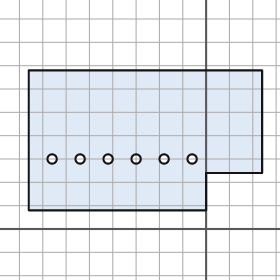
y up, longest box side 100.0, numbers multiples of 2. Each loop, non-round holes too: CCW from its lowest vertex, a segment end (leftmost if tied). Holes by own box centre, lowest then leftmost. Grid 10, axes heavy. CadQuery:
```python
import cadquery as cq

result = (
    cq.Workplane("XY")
    .moveTo(-76.0, 8.0)
    .lineTo(0.0, 8.0)
    .lineTo(0.0, 24.0)
    .lineTo(24.0, 24.0)
    .lineTo(24.0, 68.0)
    .lineTo(-76.0, 68.0)
    .close()
    .moveTo(-66.0, 30.0)
    .circle(2.0)
    .moveTo(-54.0, 30.0)
    .circle(2.0)
    .moveTo(-42.0, 30.0)
    .circle(2.0)
    .moveTo(-30.0, 30.0)
    .circle(2.0)
    .moveTo(-18.0, 30.0)
    .circle(2.0)
    .moveTo(-6.0, 30.0)
    .circle(2.0)
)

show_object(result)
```